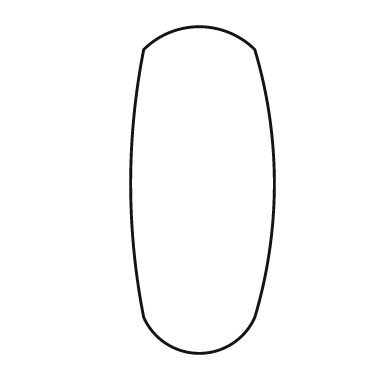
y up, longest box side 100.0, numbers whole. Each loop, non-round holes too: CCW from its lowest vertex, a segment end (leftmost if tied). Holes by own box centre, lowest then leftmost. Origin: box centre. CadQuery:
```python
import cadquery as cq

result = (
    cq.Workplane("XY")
    .moveTo(-18.0, -39.0)
    .threePointArc((-1.0, -50.0), (16.0, -39.0))
    .threePointArc((22.0, 2.0), (16.0, 43.0))
    .threePointArc((-1.0, 50.0), (-18.0, 43.0))
    .threePointArc((-22.0, 2.0), (-18.0, -39.0))
    .close()
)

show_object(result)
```